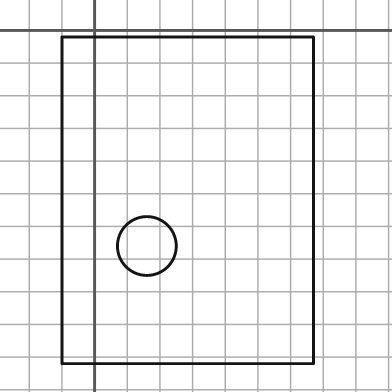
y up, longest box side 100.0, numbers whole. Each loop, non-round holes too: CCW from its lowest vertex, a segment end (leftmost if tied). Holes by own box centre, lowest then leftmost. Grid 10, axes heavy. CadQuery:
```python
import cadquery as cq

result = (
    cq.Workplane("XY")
    .moveTo(-10.0, -102.0)
    .lineTo(67.0, -102.0)
    .lineTo(67.0, -2.0)
    .lineTo(-10.0, -2.0)
    .close()
    .moveTo(16.0, -66.0)
    .circle(9.0)
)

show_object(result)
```